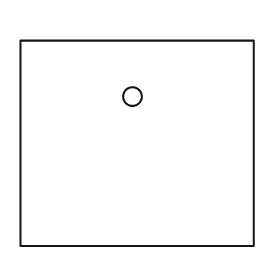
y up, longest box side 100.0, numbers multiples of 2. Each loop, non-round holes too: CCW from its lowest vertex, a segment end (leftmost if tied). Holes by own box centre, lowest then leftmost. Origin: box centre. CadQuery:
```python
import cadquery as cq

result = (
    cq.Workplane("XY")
    .moveTo(-50.0, -44.0)
    .lineTo(50.0, -44.0)
    .lineTo(50.0, 44.0)
    .lineTo(-50.0, 44.0)
    .close()
    .moveTo(-2.0, 20.0)
    .circle(4.0)
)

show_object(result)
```